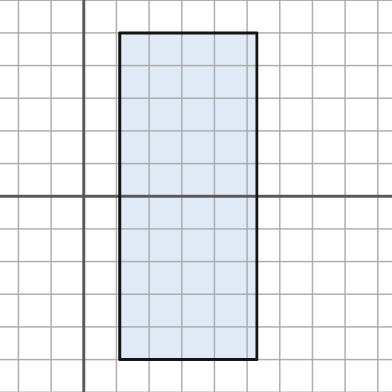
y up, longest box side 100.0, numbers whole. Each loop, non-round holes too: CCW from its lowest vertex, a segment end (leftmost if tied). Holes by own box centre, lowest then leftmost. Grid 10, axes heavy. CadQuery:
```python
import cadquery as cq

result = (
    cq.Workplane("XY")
    .moveTo(11.0, -50.0)
    .lineTo(53.0, -50.0)
    .lineTo(53.0, 50.0)
    .lineTo(11.0, 50.0)
    .close()
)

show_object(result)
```